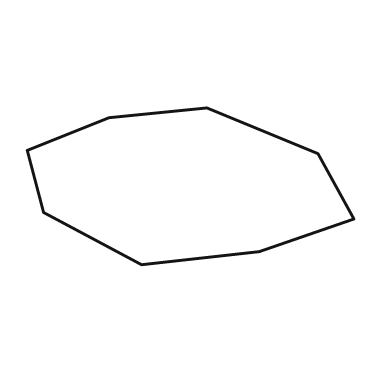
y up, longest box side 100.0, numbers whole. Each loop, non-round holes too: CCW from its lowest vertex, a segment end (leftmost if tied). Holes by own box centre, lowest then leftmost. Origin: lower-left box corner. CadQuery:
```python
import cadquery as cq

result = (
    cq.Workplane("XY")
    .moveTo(35.0, 0.0)
    .lineTo(71.0, 4.0)
    .lineTo(100.0, 14.0)
    .lineTo(89.0, 34.0)
    .lineTo(55.0, 48.0)
    .lineTo(25.0, 45.0)
    .lineTo(0.0, 35.0)
    .lineTo(5.0, 16.0)
    .close()
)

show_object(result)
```